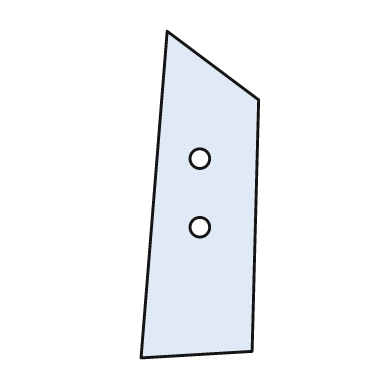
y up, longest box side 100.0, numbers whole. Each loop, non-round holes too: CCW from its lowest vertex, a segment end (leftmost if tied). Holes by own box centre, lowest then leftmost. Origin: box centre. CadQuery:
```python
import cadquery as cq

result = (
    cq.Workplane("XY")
    .moveTo(-18.0, -50.0)
    .lineTo(16.0, -48.0)
    .lineTo(18.0, 29.0)
    .lineTo(-10.0, 50.0)
    .close()
    .moveTo(0.0, -10.0)
    .circle(3.0)
    .moveTo(0.0, 11.0)
    .circle(3.0)
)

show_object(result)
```